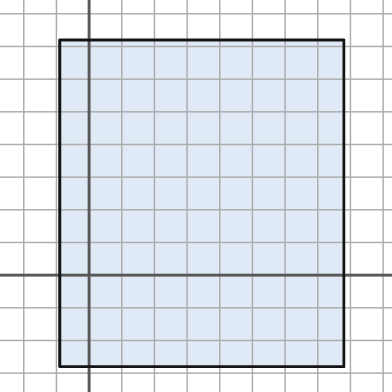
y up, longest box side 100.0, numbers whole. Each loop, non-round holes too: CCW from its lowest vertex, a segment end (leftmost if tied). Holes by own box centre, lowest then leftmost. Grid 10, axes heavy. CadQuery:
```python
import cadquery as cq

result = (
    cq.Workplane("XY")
    .moveTo(-9.0, -28.0)
    .lineTo(78.0, -28.0)
    .lineTo(78.0, 72.0)
    .lineTo(-9.0, 72.0)
    .close()
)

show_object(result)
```